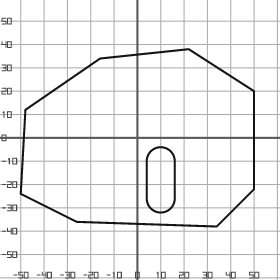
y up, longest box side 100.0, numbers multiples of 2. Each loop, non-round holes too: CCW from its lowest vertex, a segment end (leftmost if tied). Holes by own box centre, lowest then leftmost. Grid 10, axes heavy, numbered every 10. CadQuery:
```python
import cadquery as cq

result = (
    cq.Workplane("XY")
    .moveTo(34.0, -38.0)
    .lineTo(50.0, -22.0)
    .lineTo(50.0, 20.0)
    .lineTo(22.0, 38.0)
    .lineTo(-16.0, 34.0)
    .lineTo(-48.0, 12.0)
    .lineTo(-50.0, -24.0)
    .lineTo(-26.0, -36.0)
    .close()
    .moveTo(4.0, -26.0)
    .threePointArc((10.0, -32.0), (16.0, -26.0))
    .lineTo(16.0, -10.0)
    .threePointArc((10.0, -4.0), (4.0, -10.0))
    .close()
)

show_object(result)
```